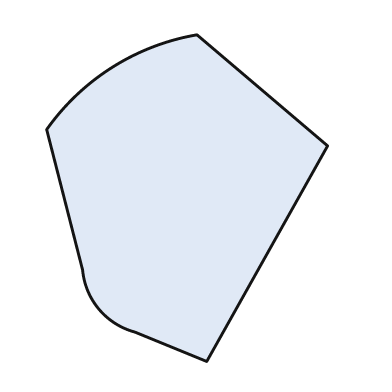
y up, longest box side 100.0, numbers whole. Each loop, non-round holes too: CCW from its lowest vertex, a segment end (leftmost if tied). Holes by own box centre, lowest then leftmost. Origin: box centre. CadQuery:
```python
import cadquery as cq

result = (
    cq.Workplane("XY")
    .moveTo(6.0, -50.0)
    .lineTo(43.0, 16.0)
    .lineTo(3.0, 50.0)
    .threePointArc((-23.0, 40.0), (-43.0, 21.0))
    .lineTo(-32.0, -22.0)
    .threePointArc((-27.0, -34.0), (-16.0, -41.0))
    .close()
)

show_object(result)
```